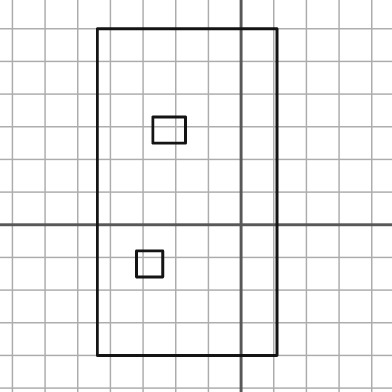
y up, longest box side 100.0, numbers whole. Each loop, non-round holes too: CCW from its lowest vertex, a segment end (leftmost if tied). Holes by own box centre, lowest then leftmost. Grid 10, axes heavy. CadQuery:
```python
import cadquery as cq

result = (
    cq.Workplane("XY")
    .moveTo(-44.0, -40.0)
    .lineTo(11.0, -40.0)
    .lineTo(11.0, 60.0)
    .lineTo(-44.0, 60.0)
    .close()
    .moveTo(-32.0, -16.0)
    .lineTo(-24.0, -16.0)
    .lineTo(-24.0, -8.0)
    .lineTo(-32.0, -8.0)
    .close()
    .moveTo(-27.0, 25.0)
    .lineTo(-17.0, 25.0)
    .lineTo(-17.0, 33.0)
    .lineTo(-27.0, 33.0)
    .close()
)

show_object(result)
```